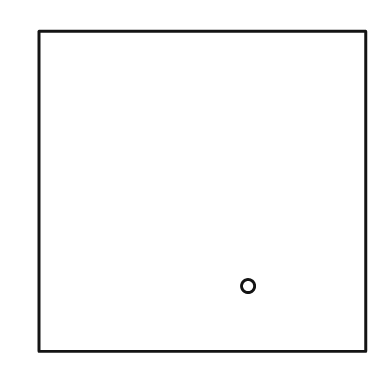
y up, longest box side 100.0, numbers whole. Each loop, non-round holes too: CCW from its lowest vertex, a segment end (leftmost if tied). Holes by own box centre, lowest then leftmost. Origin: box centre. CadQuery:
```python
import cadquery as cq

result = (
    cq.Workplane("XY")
    .moveTo(-50.0, -49.0)
    .lineTo(50.0, -49.0)
    .lineTo(50.0, 49.0)
    .lineTo(-50.0, 49.0)
    .close()
    .moveTo(14.0, -29.0)
    .circle(2.0)
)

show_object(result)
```